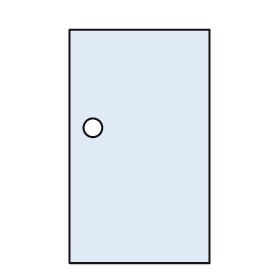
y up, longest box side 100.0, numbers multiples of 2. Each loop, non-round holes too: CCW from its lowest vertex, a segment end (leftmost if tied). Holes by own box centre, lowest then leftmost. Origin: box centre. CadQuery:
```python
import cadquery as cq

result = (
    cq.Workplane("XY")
    .moveTo(-30.0, -50.0)
    .lineTo(30.0, -50.0)
    .lineTo(30.0, 50.0)
    .lineTo(-30.0, 50.0)
    .close()
    .moveTo(-20.0, 8.0)
    .circle(4.0)
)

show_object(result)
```